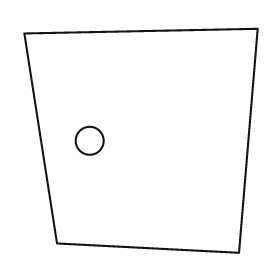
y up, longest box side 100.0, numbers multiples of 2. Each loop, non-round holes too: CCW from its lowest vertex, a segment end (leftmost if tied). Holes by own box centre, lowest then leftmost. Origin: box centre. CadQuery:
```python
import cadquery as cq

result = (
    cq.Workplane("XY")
    .moveTo(42.0, -48.0)
    .lineTo(50.0, 48.0)
    .lineTo(-50.0, 46.0)
    .lineTo(-36.0, -44.0)
    .close()
    .moveTo(-22.0, 0.0)
    .circle(6.0)
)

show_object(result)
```